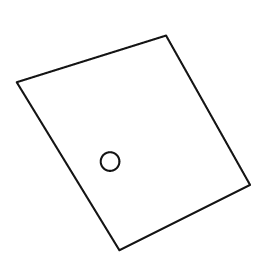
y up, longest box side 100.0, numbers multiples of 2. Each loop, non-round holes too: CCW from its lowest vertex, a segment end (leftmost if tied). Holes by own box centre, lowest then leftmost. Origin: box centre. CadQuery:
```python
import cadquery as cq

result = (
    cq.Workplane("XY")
    .moveTo(-6.0, -46.0)
    .lineTo(50.0, -18.0)
    .lineTo(14.0, 46.0)
    .lineTo(-50.0, 26.0)
    .close()
    .moveTo(-10.0, -8.0)
    .circle(4.0)
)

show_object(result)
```